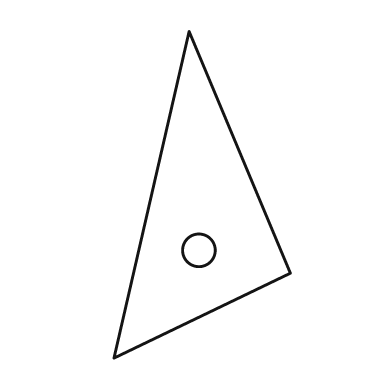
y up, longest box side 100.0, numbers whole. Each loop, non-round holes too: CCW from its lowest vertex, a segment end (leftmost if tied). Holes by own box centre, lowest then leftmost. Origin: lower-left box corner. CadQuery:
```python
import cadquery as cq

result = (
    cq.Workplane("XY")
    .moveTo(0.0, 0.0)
    .lineTo(54.0, 26.0)
    .lineTo(23.0, 100.0)
    .close()
    .moveTo(26.0, 33.0)
    .circle(5.0)
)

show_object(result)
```